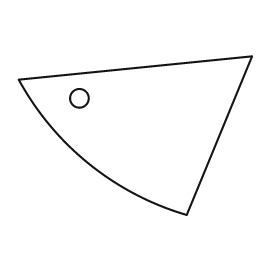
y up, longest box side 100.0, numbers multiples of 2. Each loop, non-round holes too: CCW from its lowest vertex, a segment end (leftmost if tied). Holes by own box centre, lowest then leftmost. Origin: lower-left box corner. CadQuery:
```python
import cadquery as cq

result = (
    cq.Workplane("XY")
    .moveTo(72.0, 0.0)
    .lineTo(100.0, 68.0)
    .lineTo(0.0, 58.0)
    .threePointArc((30.0, 22.0), (72.0, 0.0))
    .close()
    .moveTo(26.0, 50.0)
    .circle(4.0)
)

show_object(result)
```